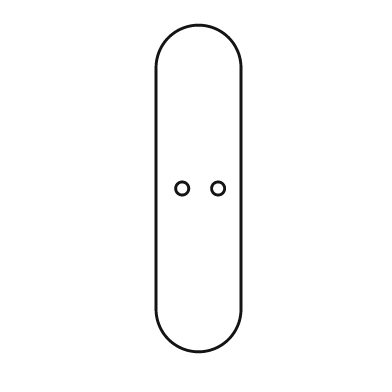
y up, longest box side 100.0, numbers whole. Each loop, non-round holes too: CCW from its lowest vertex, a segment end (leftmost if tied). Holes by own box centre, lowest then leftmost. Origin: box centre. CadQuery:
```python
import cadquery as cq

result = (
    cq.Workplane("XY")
    .moveTo(-13.0, -37.0)
    .threePointArc((0.0, -50.0), (13.0, -37.0))
    .lineTo(13.0, 37.0)
    .threePointArc((0.0, 50.0), (-13.0, 37.0))
    .close()
    .moveTo(-5.0, 0.0)
    .circle(2.0)
    .moveTo(6.0, 0.0)
    .circle(2.0)
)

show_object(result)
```